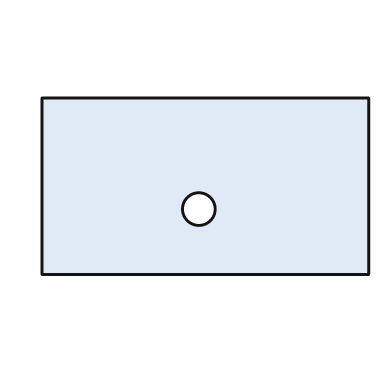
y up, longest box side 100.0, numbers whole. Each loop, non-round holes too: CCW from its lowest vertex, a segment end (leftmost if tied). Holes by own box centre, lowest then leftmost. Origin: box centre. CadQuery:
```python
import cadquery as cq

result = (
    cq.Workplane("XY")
    .moveTo(-50.0, -27.0)
    .lineTo(50.0, -27.0)
    .lineTo(50.0, 27.0)
    .lineTo(-50.0, 27.0)
    .close()
    .moveTo(-2.0, -7.0)
    .circle(5.0)
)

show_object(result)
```